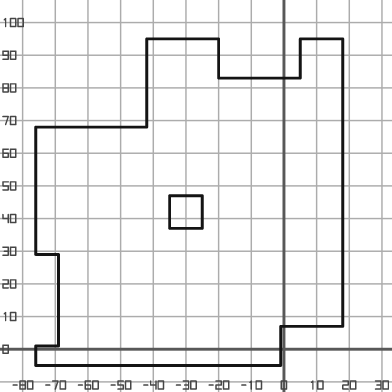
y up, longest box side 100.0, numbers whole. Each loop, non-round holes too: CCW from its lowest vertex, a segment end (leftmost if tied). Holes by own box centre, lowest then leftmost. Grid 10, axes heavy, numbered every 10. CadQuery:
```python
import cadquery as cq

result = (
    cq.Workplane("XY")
    .moveTo(-76.0, -5.0)
    .lineTo(-1.0, -5.0)
    .lineTo(-1.0, 7.0)
    .lineTo(18.0, 7.0)
    .lineTo(18.0, 95.0)
    .lineTo(5.0, 95.0)
    .lineTo(5.0, 83.0)
    .lineTo(-20.0, 83.0)
    .lineTo(-20.0, 95.0)
    .lineTo(-42.0, 95.0)
    .lineTo(-42.0, 68.0)
    .lineTo(-76.0, 68.0)
    .lineTo(-76.0, 29.0)
    .lineTo(-69.0, 29.0)
    .lineTo(-69.0, 1.0)
    .lineTo(-76.0, 1.0)
    .close()
    .moveTo(-35.0, 37.0)
    .lineTo(-25.0, 37.0)
    .lineTo(-25.0, 47.0)
    .lineTo(-35.0, 47.0)
    .close()
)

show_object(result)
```